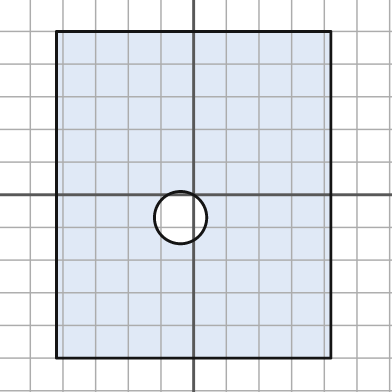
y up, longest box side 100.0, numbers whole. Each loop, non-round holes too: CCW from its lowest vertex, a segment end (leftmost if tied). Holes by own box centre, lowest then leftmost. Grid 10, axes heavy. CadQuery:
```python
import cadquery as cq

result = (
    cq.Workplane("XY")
    .moveTo(-42.0, -50.0)
    .lineTo(42.0, -50.0)
    .lineTo(42.0, 50.0)
    .lineTo(-42.0, 50.0)
    .close()
    .moveTo(-4.0, -7.0)
    .circle(8.0)
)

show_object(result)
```